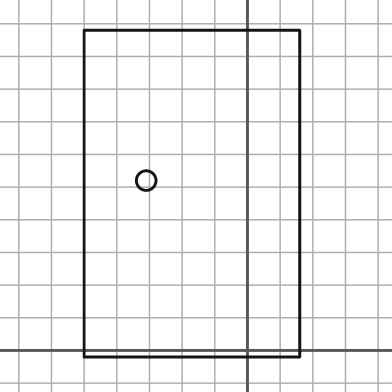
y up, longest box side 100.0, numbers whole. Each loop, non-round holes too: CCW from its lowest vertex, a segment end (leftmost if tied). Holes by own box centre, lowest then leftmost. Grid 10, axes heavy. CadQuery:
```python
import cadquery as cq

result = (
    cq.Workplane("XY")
    .moveTo(-50.0, -2.0)
    .lineTo(16.0, -2.0)
    .lineTo(16.0, 98.0)
    .lineTo(-50.0, 98.0)
    .close()
    .moveTo(-31.0, 52.0)
    .circle(3.0)
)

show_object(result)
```